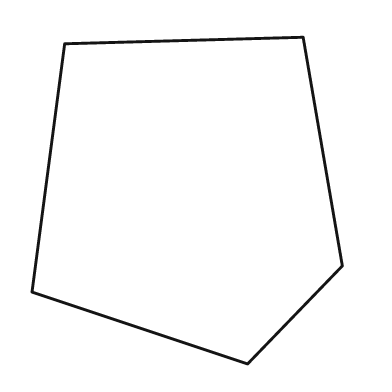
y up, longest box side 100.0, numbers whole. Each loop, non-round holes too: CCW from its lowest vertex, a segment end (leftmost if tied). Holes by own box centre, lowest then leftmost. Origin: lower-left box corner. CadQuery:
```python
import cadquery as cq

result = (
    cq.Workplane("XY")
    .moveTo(66.0, 0.0)
    .lineTo(95.0, 30.0)
    .lineTo(83.0, 100.0)
    .lineTo(10.0, 98.0)
    .lineTo(0.0, 22.0)
    .close()
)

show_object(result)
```